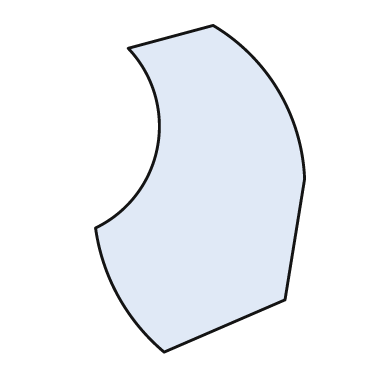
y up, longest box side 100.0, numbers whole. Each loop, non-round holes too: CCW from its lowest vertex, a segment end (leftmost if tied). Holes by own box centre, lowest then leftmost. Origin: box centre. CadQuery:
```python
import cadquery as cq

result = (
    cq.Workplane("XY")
    .moveTo(-11.0, -50.0)
    .lineTo(26.0, -34.0)
    .lineTo(32.0, 3.0)
    .threePointArc((24.0, 30.0), (4.0, 50.0))
    .lineTo(-22.0, 43.0)
    .threePointArc((-13.0, 13.0), (-32.0, -12.0))
    .threePointArc((-25.0, -33.0), (-11.0, -50.0))
    .close()
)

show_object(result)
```